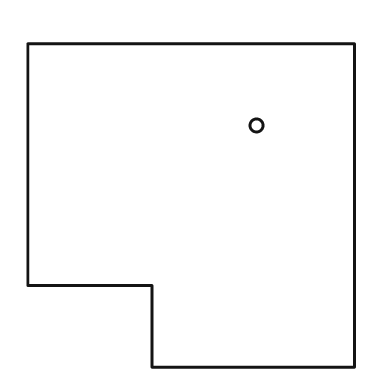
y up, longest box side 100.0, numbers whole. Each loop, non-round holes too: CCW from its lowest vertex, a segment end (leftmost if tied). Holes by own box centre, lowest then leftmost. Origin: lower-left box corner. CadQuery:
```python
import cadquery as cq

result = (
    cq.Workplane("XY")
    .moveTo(38.0, 0.0)
    .lineTo(100.0, 0.0)
    .lineTo(100.0, 99.0)
    .lineTo(0.0, 99.0)
    .lineTo(0.0, 25.0)
    .lineTo(38.0, 25.0)
    .close()
    .moveTo(70.0, 74.0)
    .circle(2.0)
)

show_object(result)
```